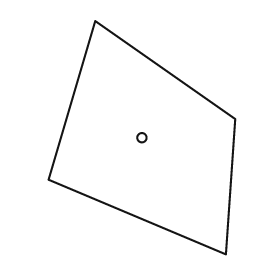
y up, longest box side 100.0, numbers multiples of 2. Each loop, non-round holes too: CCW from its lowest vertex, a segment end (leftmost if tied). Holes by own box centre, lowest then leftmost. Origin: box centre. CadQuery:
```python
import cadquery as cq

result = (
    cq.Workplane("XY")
    .moveTo(36.0, -50.0)
    .lineTo(40.0, 8.0)
    .lineTo(-20.0, 50.0)
    .lineTo(-40.0, -18.0)
    .close()
    .moveTo(0.0, 0.0)
    .circle(2.0)
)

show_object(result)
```